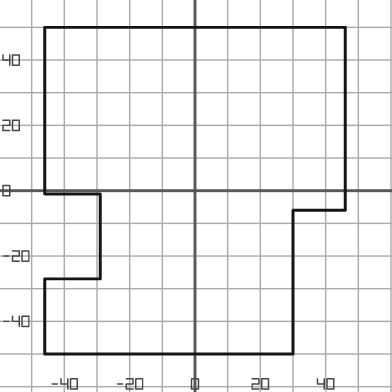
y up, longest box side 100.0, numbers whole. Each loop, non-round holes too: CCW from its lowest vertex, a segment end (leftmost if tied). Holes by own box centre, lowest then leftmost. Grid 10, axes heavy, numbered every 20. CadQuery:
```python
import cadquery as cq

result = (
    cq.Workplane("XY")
    .moveTo(-46.0, -50.0)
    .lineTo(30.0, -50.0)
    .lineTo(30.0, -6.0)
    .lineTo(46.0, -6.0)
    .lineTo(46.0, 50.0)
    .lineTo(-46.0, 50.0)
    .lineTo(-46.0, -1.0)
    .lineTo(-29.0, -1.0)
    .lineTo(-29.0, -27.0)
    .lineTo(-46.0, -27.0)
    .close()
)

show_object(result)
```